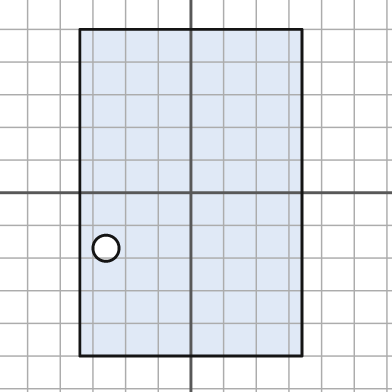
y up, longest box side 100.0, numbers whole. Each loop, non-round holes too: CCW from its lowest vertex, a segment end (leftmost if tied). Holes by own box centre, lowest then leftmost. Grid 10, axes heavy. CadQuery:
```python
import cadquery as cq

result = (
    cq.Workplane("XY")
    .moveTo(-34.0, -50.0)
    .lineTo(34.0, -50.0)
    .lineTo(34.0, 50.0)
    .lineTo(-34.0, 50.0)
    .close()
    .moveTo(-26.0, -17.0)
    .circle(4.0)
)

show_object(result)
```